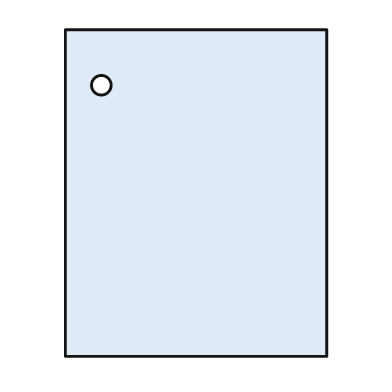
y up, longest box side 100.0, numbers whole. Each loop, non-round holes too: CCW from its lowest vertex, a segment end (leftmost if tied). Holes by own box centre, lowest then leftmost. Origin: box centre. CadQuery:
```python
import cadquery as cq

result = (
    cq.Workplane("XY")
    .moveTo(-40.0, -50.0)
    .lineTo(40.0, -50.0)
    .lineTo(40.0, 50.0)
    .lineTo(-40.0, 50.0)
    .close()
    .moveTo(-29.0, 33.0)
    .circle(3.0)
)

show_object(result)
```